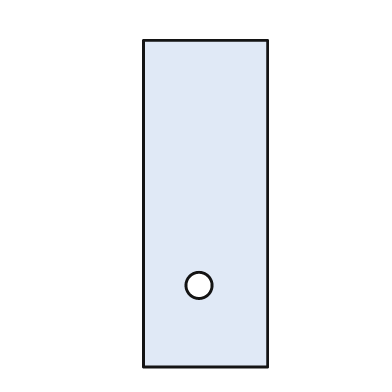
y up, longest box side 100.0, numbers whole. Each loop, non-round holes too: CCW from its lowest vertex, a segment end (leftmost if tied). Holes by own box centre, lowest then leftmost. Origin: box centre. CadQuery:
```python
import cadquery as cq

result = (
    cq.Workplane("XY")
    .moveTo(-19.0, -50.0)
    .lineTo(19.0, -50.0)
    .lineTo(19.0, 50.0)
    .lineTo(-19.0, 50.0)
    .close()
    .moveTo(-2.0, -25.0)
    .circle(4.0)
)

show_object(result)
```